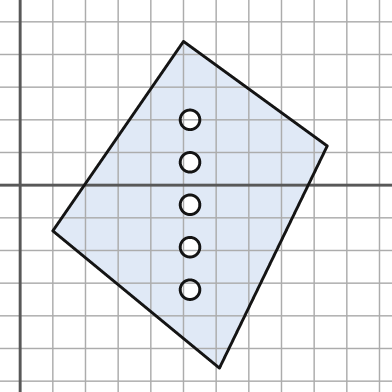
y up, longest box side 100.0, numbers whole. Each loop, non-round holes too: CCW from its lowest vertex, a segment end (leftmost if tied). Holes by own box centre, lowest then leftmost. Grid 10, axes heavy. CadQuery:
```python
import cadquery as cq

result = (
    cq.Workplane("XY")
    .moveTo(61.0, -56.0)
    .lineTo(94.0, 12.0)
    .lineTo(50.0, 44.0)
    .lineTo(10.0, -14.0)
    .close()
    .moveTo(52.0, -32.0)
    .circle(3.0)
    .moveTo(52.0, -19.0)
    .circle(3.0)
    .moveTo(52.0, -6.0)
    .circle(3.0)
    .moveTo(52.0, 7.0)
    .circle(3.0)
    .moveTo(52.0, 20.0)
    .circle(3.0)
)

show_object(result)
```